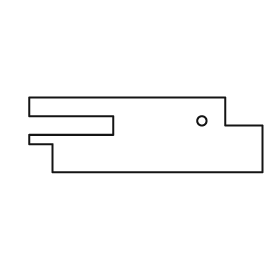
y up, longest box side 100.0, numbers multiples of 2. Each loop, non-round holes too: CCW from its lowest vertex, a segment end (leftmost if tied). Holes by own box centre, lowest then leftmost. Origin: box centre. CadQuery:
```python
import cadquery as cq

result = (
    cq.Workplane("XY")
    .moveTo(-40.0, -16.0)
    .lineTo(50.0, -16.0)
    .lineTo(50.0, 4.0)
    .lineTo(34.0, 4.0)
    .lineTo(34.0, 16.0)
    .lineTo(-50.0, 16.0)
    .lineTo(-50.0, 8.0)
    .lineTo(-14.0, 8.0)
    .lineTo(-14.0, 0.0)
    .lineTo(-50.0, 0.0)
    .lineTo(-50.0, -4.0)
    .lineTo(-40.0, -4.0)
    .close()
    .moveTo(24.0, 6.0)
    .circle(2.0)
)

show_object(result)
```